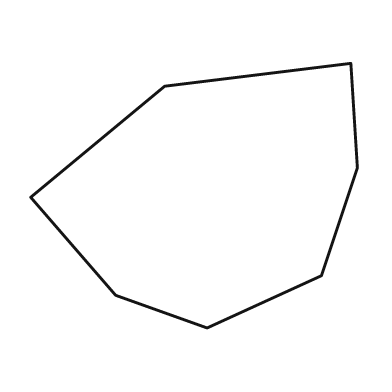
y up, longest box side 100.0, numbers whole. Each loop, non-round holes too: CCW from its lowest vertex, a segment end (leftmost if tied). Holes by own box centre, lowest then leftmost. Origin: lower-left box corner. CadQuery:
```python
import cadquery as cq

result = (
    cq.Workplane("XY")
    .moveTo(54.0, 0.0)
    .lineTo(89.0, 16.0)
    .lineTo(100.0, 49.0)
    .lineTo(98.0, 81.0)
    .lineTo(41.0, 74.0)
    .lineTo(0.0, 40.0)
    .lineTo(26.0, 10.0)
    .close()
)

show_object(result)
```